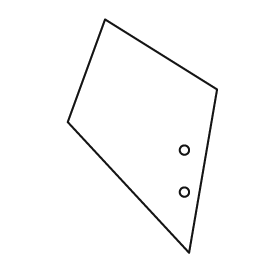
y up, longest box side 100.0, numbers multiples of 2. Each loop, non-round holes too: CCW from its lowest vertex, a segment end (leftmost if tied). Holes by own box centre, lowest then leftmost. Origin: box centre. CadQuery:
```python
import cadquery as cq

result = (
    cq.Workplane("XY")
    .moveTo(20.0, -50.0)
    .lineTo(32.0, 20.0)
    .lineTo(-16.0, 50.0)
    .lineTo(-32.0, 6.0)
    .close()
    .moveTo(18.0, -24.0)
    .circle(2.0)
    .moveTo(18.0, -6.0)
    .circle(2.0)
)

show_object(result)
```